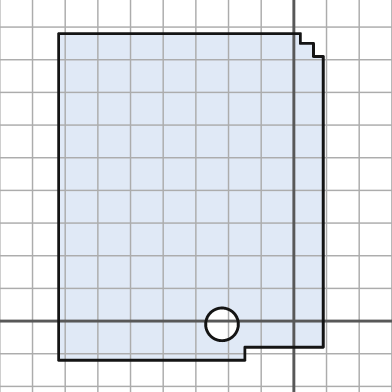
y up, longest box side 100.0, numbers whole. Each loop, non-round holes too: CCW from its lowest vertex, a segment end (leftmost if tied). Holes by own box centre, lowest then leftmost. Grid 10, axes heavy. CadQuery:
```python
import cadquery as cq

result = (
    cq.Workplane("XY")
    .moveTo(-72.0, -12.0)
    .lineTo(-15.0, -12.0)
    .lineTo(-15.0, -8.0)
    .lineTo(9.0, -8.0)
    .lineTo(9.0, 81.0)
    .lineTo(6.0, 81.0)
    .lineTo(6.0, 85.0)
    .lineTo(2.0, 85.0)
    .lineTo(2.0, 88.0)
    .lineTo(-72.0, 88.0)
    .close()
    .moveTo(-22.0, -1.0)
    .circle(5.0)
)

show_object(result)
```